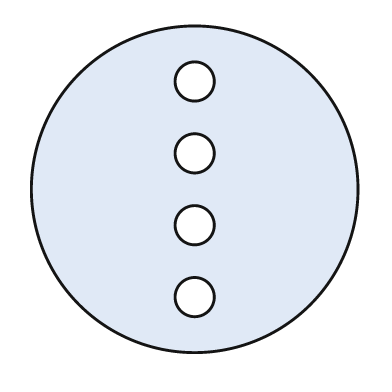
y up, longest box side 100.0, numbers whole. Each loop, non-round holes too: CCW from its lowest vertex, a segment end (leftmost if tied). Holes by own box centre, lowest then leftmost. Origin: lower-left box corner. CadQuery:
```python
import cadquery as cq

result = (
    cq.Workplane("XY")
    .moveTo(50.0, 50.0)
    .circle(50.0)
    .moveTo(50.0, 17.0)
    .circle(6.0)
    .moveTo(50.0, 39.0)
    .circle(6.0)
    .moveTo(50.0, 61.0)
    .circle(6.0)
    .moveTo(50.0, 83.0)
    .circle(6.0)
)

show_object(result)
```